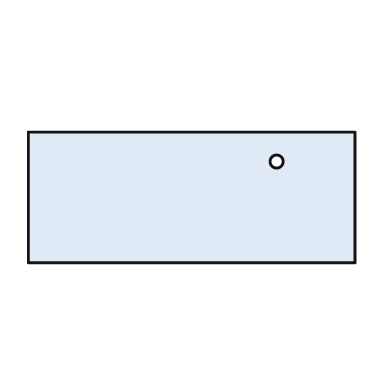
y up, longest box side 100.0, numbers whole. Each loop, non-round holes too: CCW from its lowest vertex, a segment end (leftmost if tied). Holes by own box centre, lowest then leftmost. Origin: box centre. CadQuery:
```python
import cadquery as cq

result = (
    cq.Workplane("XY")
    .moveTo(-50.0, -20.0)
    .lineTo(50.0, -20.0)
    .lineTo(50.0, 20.0)
    .lineTo(-50.0, 20.0)
    .close()
    .moveTo(26.0, 11.0)
    .circle(2.0)
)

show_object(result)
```